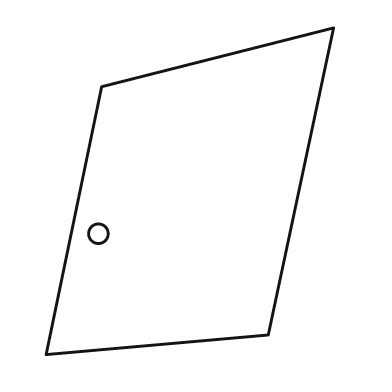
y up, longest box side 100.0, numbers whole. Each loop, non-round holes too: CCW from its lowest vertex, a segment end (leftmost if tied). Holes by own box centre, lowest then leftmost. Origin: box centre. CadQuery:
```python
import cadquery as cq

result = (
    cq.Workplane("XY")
    .moveTo(-44.0, -50.0)
    .lineTo(24.0, -44.0)
    .lineTo(44.0, 50.0)
    .lineTo(-27.0, 32.0)
    .close()
    .moveTo(-28.0, -13.0)
    .circle(3.0)
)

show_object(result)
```